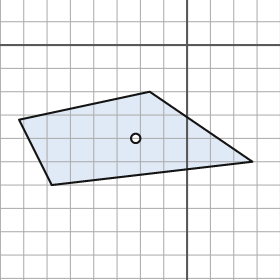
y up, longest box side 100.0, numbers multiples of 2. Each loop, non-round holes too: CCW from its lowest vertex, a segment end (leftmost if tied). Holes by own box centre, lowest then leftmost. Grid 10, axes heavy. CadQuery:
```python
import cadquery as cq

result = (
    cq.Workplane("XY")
    .moveTo(-58.0, -60.0)
    .lineTo(28.0, -50.0)
    .lineTo(-16.0, -20.0)
    .lineTo(-72.0, -32.0)
    .close()
    .moveTo(-22.0, -40.0)
    .circle(2.0)
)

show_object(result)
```